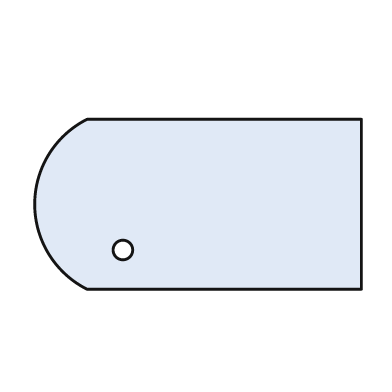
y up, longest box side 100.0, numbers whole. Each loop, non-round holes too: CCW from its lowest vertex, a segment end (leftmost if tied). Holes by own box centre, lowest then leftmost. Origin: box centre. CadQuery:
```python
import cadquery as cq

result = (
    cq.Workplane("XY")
    .moveTo(-34.0, -26.0)
    .lineTo(50.0, -26.0)
    .lineTo(50.0, 26.0)
    .lineTo(-34.0, 26.0)
    .threePointArc((-50.0, 0.0), (-34.0, -26.0))
    .close()
    .moveTo(-23.0, -14.0)
    .circle(3.0)
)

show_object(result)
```